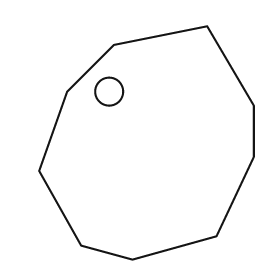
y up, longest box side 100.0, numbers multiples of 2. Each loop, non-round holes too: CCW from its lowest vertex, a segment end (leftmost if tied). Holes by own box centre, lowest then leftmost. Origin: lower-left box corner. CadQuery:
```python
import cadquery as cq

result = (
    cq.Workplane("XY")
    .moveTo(40.0, 0.0)
    .lineTo(76.0, 10.0)
    .lineTo(92.0, 44.0)
    .lineTo(92.0, 66.0)
    .lineTo(72.0, 100.0)
    .lineTo(32.0, 92.0)
    .lineTo(12.0, 72.0)
    .lineTo(0.0, 38.0)
    .lineTo(18.0, 6.0)
    .close()
    .moveTo(30.0, 72.0)
    .circle(6.0)
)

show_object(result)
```